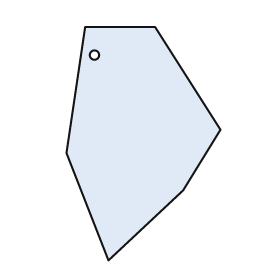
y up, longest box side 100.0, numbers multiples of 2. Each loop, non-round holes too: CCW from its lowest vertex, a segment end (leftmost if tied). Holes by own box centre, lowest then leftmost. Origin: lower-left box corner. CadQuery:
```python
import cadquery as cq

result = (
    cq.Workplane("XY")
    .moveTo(18.0, 0.0)
    .lineTo(50.0, 30.0)
    .lineTo(66.0, 56.0)
    .lineTo(38.0, 100.0)
    .lineTo(8.0, 100.0)
    .lineTo(0.0, 46.0)
    .close()
    .moveTo(12.0, 88.0)
    .circle(2.0)
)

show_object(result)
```